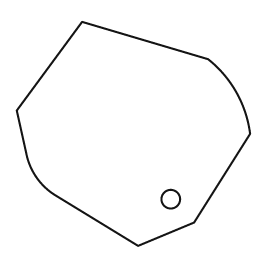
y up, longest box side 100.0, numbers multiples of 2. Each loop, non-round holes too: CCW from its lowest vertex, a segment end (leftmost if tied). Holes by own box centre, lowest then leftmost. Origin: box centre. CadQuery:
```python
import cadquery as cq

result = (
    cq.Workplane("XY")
    .moveTo(2.0, -48.0)
    .lineTo(26.0, -38.0)
    .lineTo(50.0, 0.0)
    .threePointArc((44.0, 18.0), (32.0, 32.0))
    .lineTo(-22.0, 48.0)
    .lineTo(-50.0, 10.0)
    .lineTo(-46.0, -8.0)
    .threePointArc((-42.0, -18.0), (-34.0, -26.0))
    .close()
    .moveTo(16.0, -28.0)
    .circle(4.0)
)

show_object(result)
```